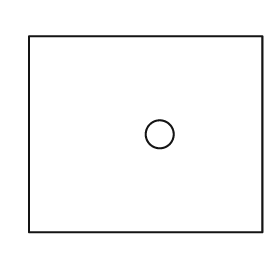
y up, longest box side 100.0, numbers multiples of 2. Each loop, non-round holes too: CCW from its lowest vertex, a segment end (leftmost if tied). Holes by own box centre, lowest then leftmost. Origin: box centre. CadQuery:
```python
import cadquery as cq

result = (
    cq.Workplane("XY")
    .moveTo(-50.0, -42.0)
    .lineTo(50.0, -42.0)
    .lineTo(50.0, 42.0)
    .lineTo(-50.0, 42.0)
    .close()
    .moveTo(6.0, 0.0)
    .circle(6.0)
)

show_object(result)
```